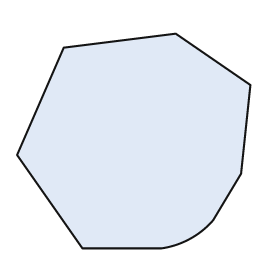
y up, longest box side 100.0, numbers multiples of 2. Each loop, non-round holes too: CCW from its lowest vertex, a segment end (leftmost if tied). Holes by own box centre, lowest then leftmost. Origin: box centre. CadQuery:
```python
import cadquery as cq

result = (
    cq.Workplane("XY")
    .moveTo(-22.0, -46.0)
    .lineTo(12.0, -46.0)
    .threePointArc((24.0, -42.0), (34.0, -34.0))
    .lineTo(46.0, -14.0)
    .lineTo(50.0, 24.0)
    .lineTo(18.0, 46.0)
    .lineTo(-30.0, 40.0)
    .lineTo(-50.0, -6.0)
    .close()
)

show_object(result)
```